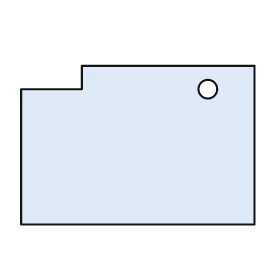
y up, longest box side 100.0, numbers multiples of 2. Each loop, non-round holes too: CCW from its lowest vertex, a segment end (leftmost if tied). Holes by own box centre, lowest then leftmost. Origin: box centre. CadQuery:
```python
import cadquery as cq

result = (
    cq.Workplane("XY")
    .moveTo(-50.0, -34.0)
    .lineTo(50.0, -34.0)
    .lineTo(50.0, 34.0)
    .lineTo(-24.0, 34.0)
    .lineTo(-24.0, 24.0)
    .lineTo(-50.0, 24.0)
    .close()
    .moveTo(30.0, 24.0)
    .circle(4.0)
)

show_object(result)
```